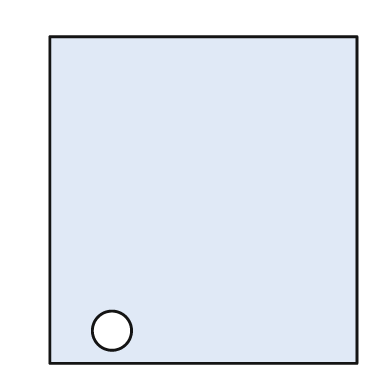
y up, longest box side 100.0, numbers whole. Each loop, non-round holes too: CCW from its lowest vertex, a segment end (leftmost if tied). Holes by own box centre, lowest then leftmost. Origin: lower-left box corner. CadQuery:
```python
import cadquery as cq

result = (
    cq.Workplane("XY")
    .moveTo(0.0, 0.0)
    .lineTo(94.0, 0.0)
    .lineTo(94.0, 100.0)
    .lineTo(0.0, 100.0)
    .close()
    .moveTo(19.0, 10.0)
    .circle(6.0)
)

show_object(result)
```